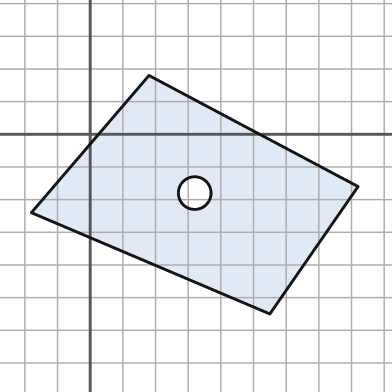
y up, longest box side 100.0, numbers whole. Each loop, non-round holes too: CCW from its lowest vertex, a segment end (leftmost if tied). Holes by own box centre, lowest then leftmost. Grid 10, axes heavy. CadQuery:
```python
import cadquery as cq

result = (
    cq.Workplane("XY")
    .moveTo(55.0, -55.0)
    .lineTo(82.0, -16.0)
    .lineTo(18.0, 18.0)
    .lineTo(-18.0, -24.0)
    .close()
    .moveTo(32.0, -18.0)
    .circle(5.0)
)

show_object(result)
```